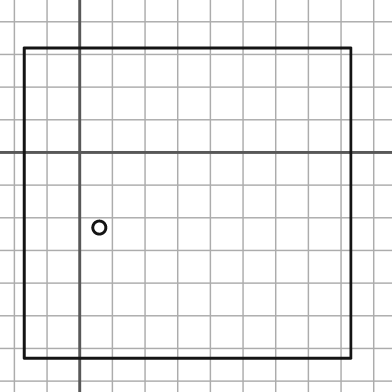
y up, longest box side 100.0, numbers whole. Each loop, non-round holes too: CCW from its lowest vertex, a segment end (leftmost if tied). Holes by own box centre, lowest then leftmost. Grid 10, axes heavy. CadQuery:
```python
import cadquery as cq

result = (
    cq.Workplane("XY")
    .moveTo(-17.0, -63.0)
    .lineTo(83.0, -63.0)
    .lineTo(83.0, 32.0)
    .lineTo(-17.0, 32.0)
    .close()
    .moveTo(6.0, -23.0)
    .circle(2.0)
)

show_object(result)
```